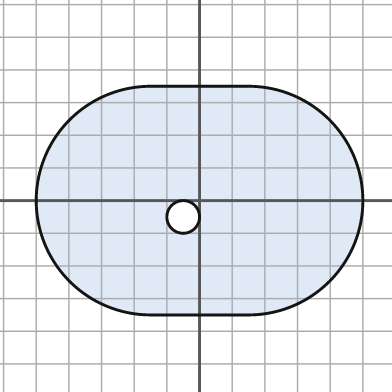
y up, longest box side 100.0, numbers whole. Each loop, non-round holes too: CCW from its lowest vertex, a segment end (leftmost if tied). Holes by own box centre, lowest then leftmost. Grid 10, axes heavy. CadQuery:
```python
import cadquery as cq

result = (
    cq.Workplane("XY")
    .moveTo(-15.0, -35.0)
    .lineTo(15.0, -35.0)
    .threePointArc((50.0, 0.0), (15.0, 35.0))
    .lineTo(-15.0, 35.0)
    .threePointArc((-50.0, 0.0), (-15.0, -35.0))
    .close()
    .moveTo(-5.0, -5.0)
    .circle(5.0)
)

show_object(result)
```